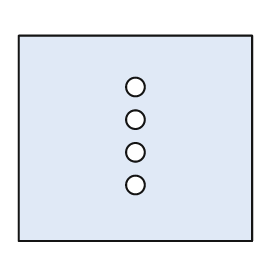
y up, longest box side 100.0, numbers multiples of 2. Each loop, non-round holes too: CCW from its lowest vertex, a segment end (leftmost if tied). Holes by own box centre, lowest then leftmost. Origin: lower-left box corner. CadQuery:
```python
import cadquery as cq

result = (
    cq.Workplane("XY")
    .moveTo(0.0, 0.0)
    .lineTo(100.0, 0.0)
    .lineTo(100.0, 88.0)
    .lineTo(0.0, 88.0)
    .close()
    .moveTo(50.0, 24.0)
    .circle(4.0)
    .moveTo(50.0, 38.0)
    .circle(4.0)
    .moveTo(50.0, 52.0)
    .circle(4.0)
    .moveTo(50.0, 66.0)
    .circle(4.0)
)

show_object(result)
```